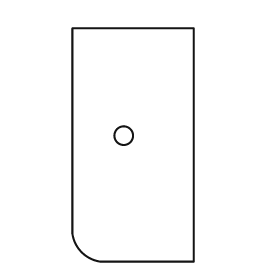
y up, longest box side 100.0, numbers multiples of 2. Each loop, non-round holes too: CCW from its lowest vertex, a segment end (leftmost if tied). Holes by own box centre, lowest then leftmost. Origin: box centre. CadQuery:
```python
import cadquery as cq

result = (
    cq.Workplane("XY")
    .moveTo(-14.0, -50.0)
    .lineTo(26.0, -50.0)
    .lineTo(26.0, 50.0)
    .lineTo(-26.0, 50.0)
    .lineTo(-26.0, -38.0)
    .threePointArc((-22.0, -46.0), (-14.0, -50.0))
    .close()
    .moveTo(-4.0, 4.0)
    .circle(4.0)
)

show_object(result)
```